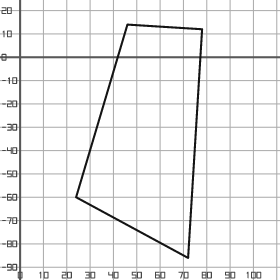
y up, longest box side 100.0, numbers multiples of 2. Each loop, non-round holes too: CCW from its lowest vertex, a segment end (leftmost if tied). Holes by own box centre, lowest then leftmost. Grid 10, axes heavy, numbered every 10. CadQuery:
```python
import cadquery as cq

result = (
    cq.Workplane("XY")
    .moveTo(72.0, -86.0)
    .lineTo(78.0, 12.0)
    .lineTo(46.0, 14.0)
    .lineTo(24.0, -60.0)
    .close()
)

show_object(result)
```